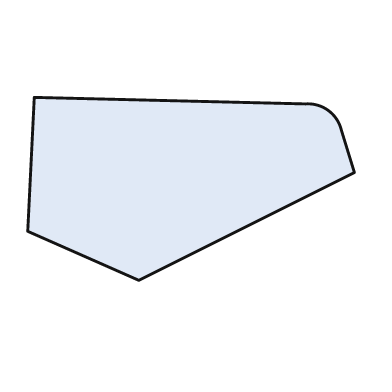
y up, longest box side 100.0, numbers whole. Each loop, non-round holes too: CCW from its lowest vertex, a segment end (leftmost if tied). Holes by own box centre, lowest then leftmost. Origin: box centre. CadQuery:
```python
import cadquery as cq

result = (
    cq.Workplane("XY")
    .moveTo(-16.0, -28.0)
    .lineTo(50.0, 5.0)
    .lineTo(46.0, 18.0)
    .threePointArc((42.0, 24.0), (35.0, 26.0))
    .lineTo(-48.0, 28.0)
    .lineTo(-50.0, -13.0)
    .close()
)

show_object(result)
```